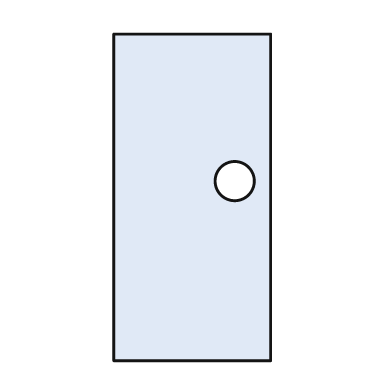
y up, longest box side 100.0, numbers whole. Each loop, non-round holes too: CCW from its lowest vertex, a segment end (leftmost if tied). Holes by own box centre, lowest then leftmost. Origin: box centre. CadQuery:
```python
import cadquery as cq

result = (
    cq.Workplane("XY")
    .moveTo(-24.0, -50.0)
    .lineTo(24.0, -50.0)
    .lineTo(24.0, 50.0)
    .lineTo(-24.0, 50.0)
    .close()
    .moveTo(13.0, 5.0)
    .circle(6.0)
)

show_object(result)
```